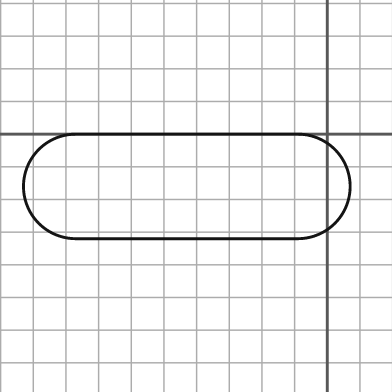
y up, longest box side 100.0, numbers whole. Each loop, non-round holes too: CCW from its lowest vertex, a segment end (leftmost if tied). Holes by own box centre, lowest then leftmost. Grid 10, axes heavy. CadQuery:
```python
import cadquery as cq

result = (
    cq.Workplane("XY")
    .moveTo(-77.0, -32.0)
    .lineTo(-9.0, -32.0)
    .threePointArc((7.0, -16.0), (-9.0, 0.0))
    .lineTo(-77.0, 0.0)
    .threePointArc((-93.0, -16.0), (-77.0, -32.0))
    .close()
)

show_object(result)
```